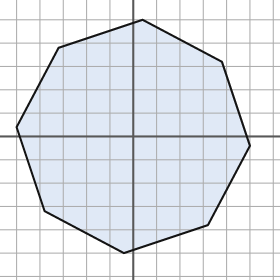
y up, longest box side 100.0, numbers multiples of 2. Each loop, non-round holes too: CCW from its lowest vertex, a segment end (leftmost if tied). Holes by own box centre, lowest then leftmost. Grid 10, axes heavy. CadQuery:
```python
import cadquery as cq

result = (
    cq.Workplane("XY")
    .moveTo(-4.0, -50.0)
    .lineTo(32.0, -38.0)
    .lineTo(50.0, -4.0)
    .lineTo(38.0, 32.0)
    .lineTo(4.0, 50.0)
    .lineTo(-32.0, 38.0)
    .lineTo(-50.0, 4.0)
    .lineTo(-38.0, -32.0)
    .close()
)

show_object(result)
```